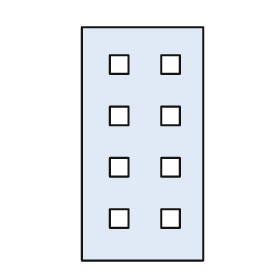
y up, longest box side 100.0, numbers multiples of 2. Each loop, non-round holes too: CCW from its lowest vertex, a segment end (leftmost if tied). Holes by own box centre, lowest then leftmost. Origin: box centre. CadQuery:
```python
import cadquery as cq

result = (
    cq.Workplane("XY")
    .moveTo(-26.0, -50.0)
    .lineTo(26.0, -50.0)
    .lineTo(26.0, 50.0)
    .lineTo(-26.0, 50.0)
    .close()
    .moveTo(-14.0, -36.0)
    .lineTo(-6.0, -36.0)
    .lineTo(-6.0, -28.0)
    .lineTo(-14.0, -28.0)
    .close()
    .moveTo(8.0, -36.0)
    .lineTo(16.0, -36.0)
    .lineTo(16.0, -28.0)
    .lineTo(8.0, -28.0)
    .close()
    .moveTo(-14.0, -14.0)
    .lineTo(-6.0, -14.0)
    .lineTo(-6.0, -6.0)
    .lineTo(-14.0, -6.0)
    .close()
    .moveTo(8.0, -14.0)
    .lineTo(16.0, -14.0)
    .lineTo(16.0, -6.0)
    .lineTo(8.0, -6.0)
    .close()
    .moveTo(-14.0, 8.0)
    .lineTo(-6.0, 8.0)
    .lineTo(-6.0, 16.0)
    .lineTo(-14.0, 16.0)
    .close()
    .moveTo(8.0, 8.0)
    .lineTo(16.0, 8.0)
    .lineTo(16.0, 16.0)
    .lineTo(8.0, 16.0)
    .close()
    .moveTo(-14.0, 30.0)
    .lineTo(-6.0, 30.0)
    .lineTo(-6.0, 38.0)
    .lineTo(-14.0, 38.0)
    .close()
    .moveTo(8.0, 30.0)
    .lineTo(16.0, 30.0)
    .lineTo(16.0, 38.0)
    .lineTo(8.0, 38.0)
    .close()
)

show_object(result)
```